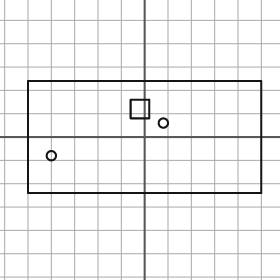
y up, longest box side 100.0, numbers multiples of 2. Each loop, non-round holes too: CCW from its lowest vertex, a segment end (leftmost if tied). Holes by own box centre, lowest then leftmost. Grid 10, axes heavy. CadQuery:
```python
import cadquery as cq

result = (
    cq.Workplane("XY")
    .moveTo(-50.0, -24.0)
    .lineTo(50.0, -24.0)
    .lineTo(50.0, 24.0)
    .lineTo(-50.0, 24.0)
    .close()
    .moveTo(-40.0, -8.0)
    .circle(2.0)
    .moveTo(8.0, 6.0)
    .circle(2.0)
    .moveTo(-6.0, 8.0)
    .lineTo(2.0, 8.0)
    .lineTo(2.0, 16.0)
    .lineTo(-6.0, 16.0)
    .close()
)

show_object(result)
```